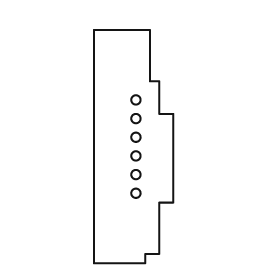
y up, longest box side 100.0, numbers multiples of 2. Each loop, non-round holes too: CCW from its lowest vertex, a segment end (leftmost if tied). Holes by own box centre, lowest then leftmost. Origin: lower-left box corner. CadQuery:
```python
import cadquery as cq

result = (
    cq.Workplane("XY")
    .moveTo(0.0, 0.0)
    .lineTo(22.0, 0.0)
    .lineTo(22.0, 4.0)
    .lineTo(28.0, 4.0)
    .lineTo(28.0, 26.0)
    .lineTo(34.0, 26.0)
    .lineTo(34.0, 64.0)
    .lineTo(28.0, 64.0)
    .lineTo(28.0, 78.0)
    .lineTo(24.0, 78.0)
    .lineTo(24.0, 100.0)
    .lineTo(0.0, 100.0)
    .close()
    .moveTo(18.0, 30.0)
    .circle(2.0)
    .moveTo(18.0, 38.0)
    .circle(2.0)
    .moveTo(18.0, 46.0)
    .circle(2.0)
    .moveTo(18.0, 54.0)
    .circle(2.0)
    .moveTo(18.0, 62.0)
    .circle(2.0)
    .moveTo(18.0, 70.0)
    .circle(2.0)
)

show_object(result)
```